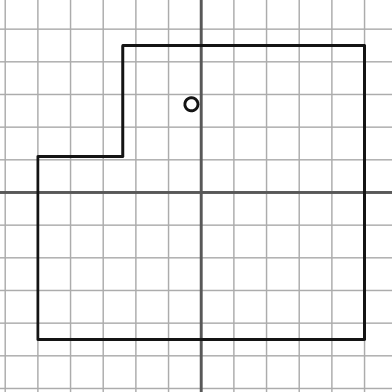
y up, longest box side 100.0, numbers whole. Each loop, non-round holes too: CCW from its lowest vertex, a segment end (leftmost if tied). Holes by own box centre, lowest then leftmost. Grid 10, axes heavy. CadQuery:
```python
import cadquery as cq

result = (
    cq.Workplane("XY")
    .moveTo(-50.0, -45.0)
    .lineTo(50.0, -45.0)
    .lineTo(50.0, 45.0)
    .lineTo(-24.0, 45.0)
    .lineTo(-24.0, 11.0)
    .lineTo(-50.0, 11.0)
    .close()
    .moveTo(-3.0, 27.0)
    .circle(2.0)
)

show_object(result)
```